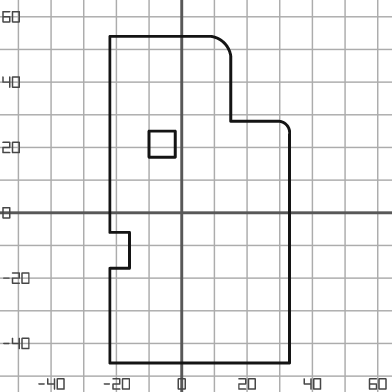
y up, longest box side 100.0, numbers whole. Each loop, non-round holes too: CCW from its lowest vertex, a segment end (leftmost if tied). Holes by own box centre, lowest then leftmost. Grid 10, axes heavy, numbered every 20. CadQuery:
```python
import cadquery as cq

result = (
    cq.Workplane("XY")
    .moveTo(-22.0, -46.0)
    .lineTo(33.0, -46.0)
    .lineTo(33.0, 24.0)
    .threePointArc((32.0, 27.0), (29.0, 28.0))
    .lineTo(15.0, 28.0)
    .lineTo(15.0, 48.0)
    .threePointArc((13.0, 52.0), (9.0, 54.0))
    .lineTo(-22.0, 54.0)
    .lineTo(-22.0, -6.0)
    .lineTo(-16.0, -6.0)
    .lineTo(-16.0, -17.0)
    .lineTo(-22.0, -17.0)
    .close()
    .moveTo(-10.0, 17.0)
    .lineTo(-2.0, 17.0)
    .lineTo(-2.0, 25.0)
    .lineTo(-10.0, 25.0)
    .close()
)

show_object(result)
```